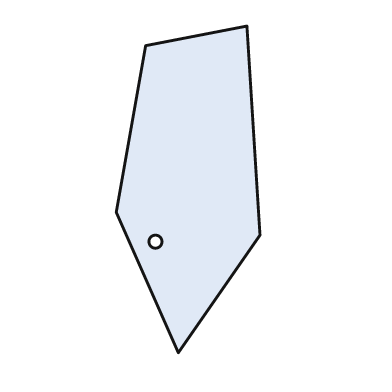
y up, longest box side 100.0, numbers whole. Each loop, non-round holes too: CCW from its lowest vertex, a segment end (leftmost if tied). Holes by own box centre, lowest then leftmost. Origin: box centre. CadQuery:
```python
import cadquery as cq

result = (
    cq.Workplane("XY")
    .moveTo(-3.0, -50.0)
    .lineTo(22.0, -14.0)
    .lineTo(18.0, 50.0)
    .lineTo(-13.0, 44.0)
    .lineTo(-22.0, -7.0)
    .close()
    .moveTo(-10.0, -16.0)
    .circle(2.0)
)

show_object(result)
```